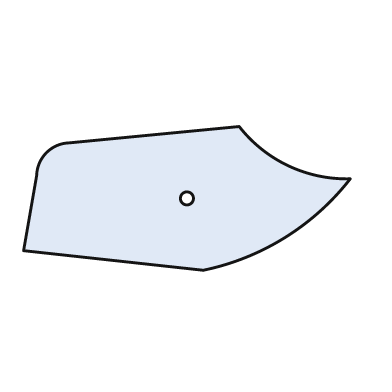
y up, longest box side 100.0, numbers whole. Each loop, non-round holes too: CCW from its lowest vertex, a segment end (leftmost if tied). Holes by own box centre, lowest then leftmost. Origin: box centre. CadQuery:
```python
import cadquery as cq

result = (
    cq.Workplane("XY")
    .moveTo(5.0, -22.0)
    .threePointArc((30.0, -12.0), (50.0, 6.0))
    .threePointArc((31.0, 10.0), (16.0, 22.0))
    .lineTo(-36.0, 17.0)
    .threePointArc((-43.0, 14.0), (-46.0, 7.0))
    .lineTo(-50.0, -16.0)
    .close()
    .moveTo(0.0, 0.0)
    .circle(2.0)
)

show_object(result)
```